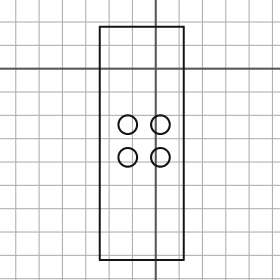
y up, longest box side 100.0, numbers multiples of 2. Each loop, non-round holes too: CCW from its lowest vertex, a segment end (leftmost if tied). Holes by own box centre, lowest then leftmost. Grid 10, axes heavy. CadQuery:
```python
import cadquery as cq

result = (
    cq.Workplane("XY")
    .moveTo(-24.0, -82.0)
    .lineTo(12.0, -82.0)
    .lineTo(12.0, 18.0)
    .lineTo(-24.0, 18.0)
    .close()
    .moveTo(-12.0, -38.0)
    .circle(4.0)
    .moveTo(2.0, -38.0)
    .circle(4.0)
    .moveTo(-12.0, -24.0)
    .circle(4.0)
    .moveTo(2.0, -24.0)
    .circle(4.0)
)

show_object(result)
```